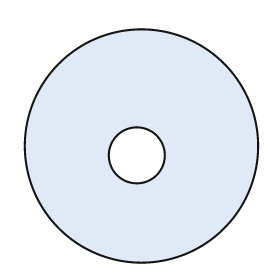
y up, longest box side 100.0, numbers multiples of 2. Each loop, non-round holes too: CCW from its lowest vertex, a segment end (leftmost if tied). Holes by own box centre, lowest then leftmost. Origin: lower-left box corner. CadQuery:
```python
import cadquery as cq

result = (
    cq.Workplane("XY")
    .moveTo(50.0, 50.0)
    .circle(50.0)
    .moveTo(48.0, 46.0)
    .circle(12.0)
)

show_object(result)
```